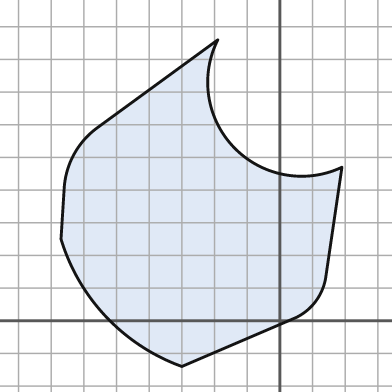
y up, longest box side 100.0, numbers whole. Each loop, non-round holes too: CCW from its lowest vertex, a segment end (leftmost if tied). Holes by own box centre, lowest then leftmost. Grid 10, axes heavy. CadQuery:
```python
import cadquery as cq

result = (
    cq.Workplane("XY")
    .moveTo(-30.0, -14.0)
    .lineTo(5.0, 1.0)
    .threePointArc((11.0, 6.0), (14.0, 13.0))
    .lineTo(19.0, 47.0)
    .threePointArc((-14.0, 53.0), (-19.0, 86.0))
    .lineTo(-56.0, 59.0)
    .threePointArc((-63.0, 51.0), (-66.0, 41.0))
    .lineTo(-67.0, 25.0)
    .threePointArc((-53.0, 1.0), (-30.0, -14.0))
    .close()
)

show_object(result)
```